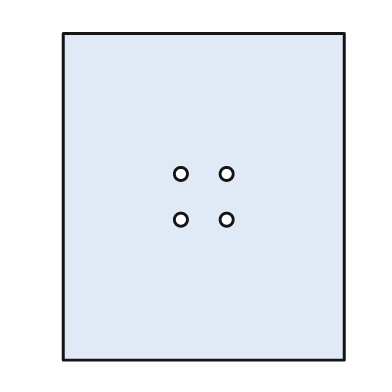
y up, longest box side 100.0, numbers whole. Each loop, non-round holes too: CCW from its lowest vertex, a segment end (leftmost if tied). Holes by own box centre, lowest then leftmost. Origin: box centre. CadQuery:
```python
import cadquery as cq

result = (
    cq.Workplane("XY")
    .moveTo(-43.0, -50.0)
    .lineTo(43.0, -50.0)
    .lineTo(43.0, 50.0)
    .lineTo(-43.0, 50.0)
    .close()
    .moveTo(-7.0, -7.0)
    .circle(2.0)
    .moveTo(7.0, -7.0)
    .circle(2.0)
    .moveTo(-7.0, 7.0)
    .circle(2.0)
    .moveTo(7.0, 7.0)
    .circle(2.0)
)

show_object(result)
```